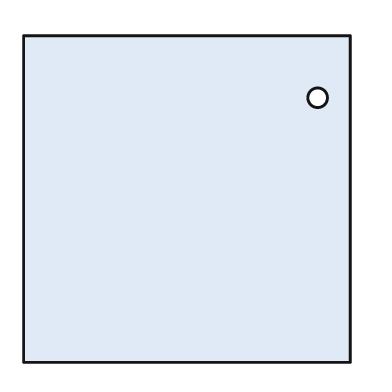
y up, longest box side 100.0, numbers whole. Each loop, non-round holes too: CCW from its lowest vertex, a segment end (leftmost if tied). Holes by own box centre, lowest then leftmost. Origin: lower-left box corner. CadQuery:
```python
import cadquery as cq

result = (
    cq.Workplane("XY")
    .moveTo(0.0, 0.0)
    .lineTo(100.0, 0.0)
    .lineTo(100.0, 100.0)
    .lineTo(0.0, 100.0)
    .close()
    .moveTo(90.0, 81.0)
    .circle(3.0)
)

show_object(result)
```